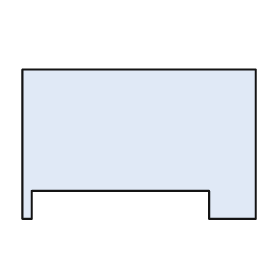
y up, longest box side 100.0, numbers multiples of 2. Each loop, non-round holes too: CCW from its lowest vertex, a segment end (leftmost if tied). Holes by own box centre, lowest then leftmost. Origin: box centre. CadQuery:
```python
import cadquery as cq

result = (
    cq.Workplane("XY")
    .moveTo(-50.0, -32.0)
    .lineTo(-46.0, -32.0)
    .lineTo(-46.0, -20.0)
    .lineTo(30.0, -20.0)
    .lineTo(30.0, -32.0)
    .lineTo(50.0, -32.0)
    .lineTo(50.0, 32.0)
    .lineTo(-50.0, 32.0)
    .close()
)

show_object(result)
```